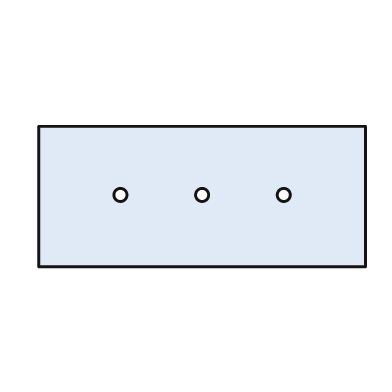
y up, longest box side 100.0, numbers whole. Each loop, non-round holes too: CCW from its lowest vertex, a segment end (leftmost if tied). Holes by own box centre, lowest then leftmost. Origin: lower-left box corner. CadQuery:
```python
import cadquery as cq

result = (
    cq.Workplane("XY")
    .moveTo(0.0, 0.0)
    .lineTo(100.0, 0.0)
    .lineTo(100.0, 43.0)
    .lineTo(0.0, 43.0)
    .close()
    .moveTo(25.0, 22.0)
    .circle(2.0)
    .moveTo(50.0, 22.0)
    .circle(2.0)
    .moveTo(75.0, 22.0)
    .circle(2.0)
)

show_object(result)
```